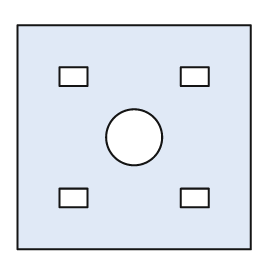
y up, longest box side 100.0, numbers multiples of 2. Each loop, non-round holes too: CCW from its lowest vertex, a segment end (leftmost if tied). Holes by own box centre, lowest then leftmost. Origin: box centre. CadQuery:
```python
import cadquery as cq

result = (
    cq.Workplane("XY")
    .moveTo(-50.0, -48.0)
    .lineTo(50.0, -48.0)
    .lineTo(50.0, 48.0)
    .lineTo(-50.0, 48.0)
    .close()
    .moveTo(-32.0, -30.0)
    .lineTo(-20.0, -30.0)
    .lineTo(-20.0, -22.0)
    .lineTo(-32.0, -22.0)
    .close()
    .moveTo(20.0, -30.0)
    .lineTo(32.0, -30.0)
    .lineTo(32.0, -22.0)
    .lineTo(20.0, -22.0)
    .close()
    .moveTo(0.0, 0.0)
    .circle(12.0)
    .moveTo(-32.0, 22.0)
    .lineTo(-20.0, 22.0)
    .lineTo(-20.0, 30.0)
    .lineTo(-32.0, 30.0)
    .close()
    .moveTo(20.0, 22.0)
    .lineTo(32.0, 22.0)
    .lineTo(32.0, 30.0)
    .lineTo(20.0, 30.0)
    .close()
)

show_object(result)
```